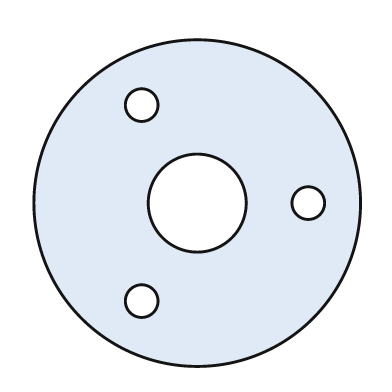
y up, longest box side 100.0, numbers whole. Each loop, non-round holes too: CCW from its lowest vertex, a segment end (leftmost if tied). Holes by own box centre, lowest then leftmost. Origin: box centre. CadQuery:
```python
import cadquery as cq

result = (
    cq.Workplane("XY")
    .moveTo(0.0, 0.0)
    .circle(50.0)
    .moveTo(-17.0, -30.0)
    .circle(5.0)
    .moveTo(0.0, 0.0)
    .circle(15.0)
    .moveTo(34.0, 0.0)
    .circle(5.0)
    .moveTo(-17.0, 30.0)
    .circle(5.0)
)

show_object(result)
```